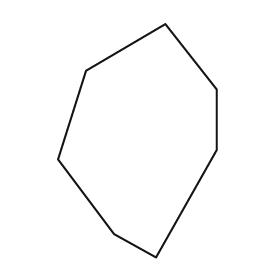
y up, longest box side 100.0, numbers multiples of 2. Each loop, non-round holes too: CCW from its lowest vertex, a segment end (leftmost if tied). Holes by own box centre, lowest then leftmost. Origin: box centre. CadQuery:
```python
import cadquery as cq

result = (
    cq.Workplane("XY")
    .moveTo(8.0, -50.0)
    .lineTo(34.0, -4.0)
    .lineTo(34.0, 22.0)
    .lineTo(12.0, 50.0)
    .lineTo(-22.0, 30.0)
    .lineTo(-34.0, -8.0)
    .lineTo(-10.0, -40.0)
    .close()
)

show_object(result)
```